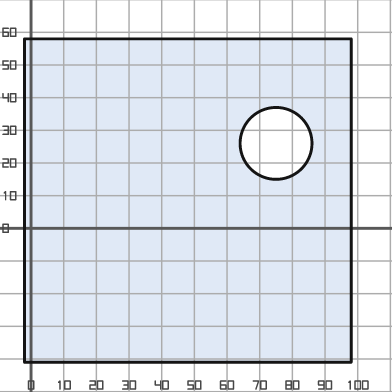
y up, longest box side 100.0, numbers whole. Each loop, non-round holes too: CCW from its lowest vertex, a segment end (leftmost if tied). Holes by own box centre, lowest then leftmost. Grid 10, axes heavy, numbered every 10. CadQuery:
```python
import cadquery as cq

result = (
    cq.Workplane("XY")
    .moveTo(-2.0, -41.0)
    .lineTo(98.0, -41.0)
    .lineTo(98.0, 58.0)
    .lineTo(-2.0, 58.0)
    .close()
    .moveTo(75.0, 26.0)
    .circle(11.0)
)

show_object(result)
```